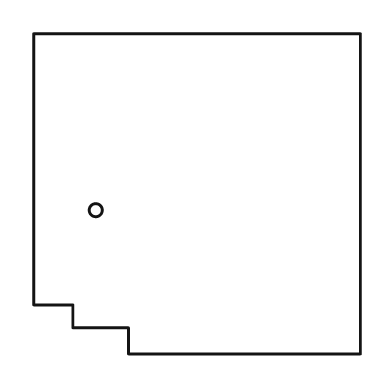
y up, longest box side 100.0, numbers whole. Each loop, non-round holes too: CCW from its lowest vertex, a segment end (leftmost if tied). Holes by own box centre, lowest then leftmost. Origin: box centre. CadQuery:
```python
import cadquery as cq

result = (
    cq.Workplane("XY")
    .moveTo(-21.0, -49.0)
    .lineTo(50.0, -49.0)
    .lineTo(50.0, 49.0)
    .lineTo(-50.0, 49.0)
    .lineTo(-50.0, -34.0)
    .lineTo(-38.0, -34.0)
    .lineTo(-38.0, -41.0)
    .lineTo(-21.0, -41.0)
    .close()
    .moveTo(-31.0, -5.0)
    .circle(2.0)
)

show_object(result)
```